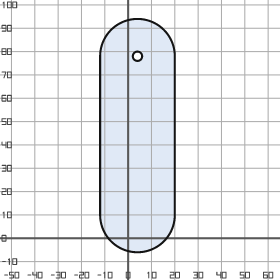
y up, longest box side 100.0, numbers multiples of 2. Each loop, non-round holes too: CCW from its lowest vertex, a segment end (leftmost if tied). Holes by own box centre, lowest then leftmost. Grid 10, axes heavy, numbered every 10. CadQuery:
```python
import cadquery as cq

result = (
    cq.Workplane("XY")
    .moveTo(-12.0, 10.0)
    .threePointArc((4.0, -6.0), (20.0, 10.0))
    .lineTo(20.0, 78.0)
    .threePointArc((4.0, 94.0), (-12.0, 78.0))
    .close()
    .moveTo(4.0, 78.0)
    .circle(2.0)
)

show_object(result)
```